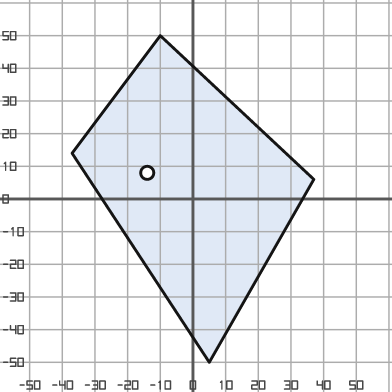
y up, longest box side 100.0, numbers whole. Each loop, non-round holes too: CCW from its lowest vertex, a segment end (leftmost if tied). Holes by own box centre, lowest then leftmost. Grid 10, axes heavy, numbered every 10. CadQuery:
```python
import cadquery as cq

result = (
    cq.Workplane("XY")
    .moveTo(5.0, -50.0)
    .lineTo(37.0, 6.0)
    .lineTo(-10.0, 50.0)
    .lineTo(-37.0, 14.0)
    .close()
    .moveTo(-14.0, 8.0)
    .circle(2.0)
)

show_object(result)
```